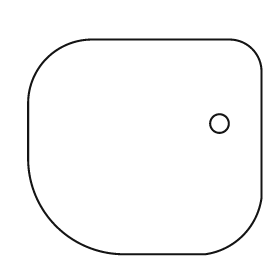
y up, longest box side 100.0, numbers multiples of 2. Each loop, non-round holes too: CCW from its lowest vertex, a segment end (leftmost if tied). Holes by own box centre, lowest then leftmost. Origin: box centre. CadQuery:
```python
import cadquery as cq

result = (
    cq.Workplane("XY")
    .moveTo(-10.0, -46.0)
    .lineTo(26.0, -46.0)
    .threePointArc((42.0, -38.0), (50.0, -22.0))
    .lineTo(50.0, 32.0)
    .threePointArc((46.0, 42.0), (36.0, 46.0))
    .lineTo(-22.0, 46.0)
    .threePointArc((-42.0, 38.0), (-50.0, 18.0))
    .lineTo(-50.0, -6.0)
    .threePointArc((-38.0, -34.0), (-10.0, -46.0))
    .close()
    .moveTo(32.0, 10.0)
    .circle(4.0)
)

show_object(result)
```